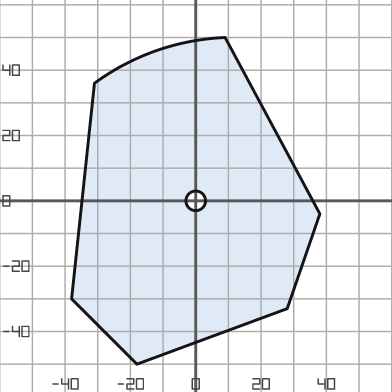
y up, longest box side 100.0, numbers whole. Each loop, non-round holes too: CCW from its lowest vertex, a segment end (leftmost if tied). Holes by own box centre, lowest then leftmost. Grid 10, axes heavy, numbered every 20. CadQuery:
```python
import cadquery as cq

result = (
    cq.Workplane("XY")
    .moveTo(-18.0, -50.0)
    .lineTo(28.0, -33.0)
    .lineTo(38.0, -4.0)
    .lineTo(9.0, 50.0)
    .threePointArc((-12.0, 46.0), (-31.0, 36.0))
    .lineTo(-38.0, -30.0)
    .close()
    .moveTo(0.0, 0.0)
    .circle(3.0)
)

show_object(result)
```